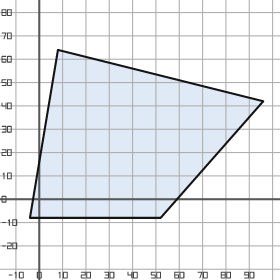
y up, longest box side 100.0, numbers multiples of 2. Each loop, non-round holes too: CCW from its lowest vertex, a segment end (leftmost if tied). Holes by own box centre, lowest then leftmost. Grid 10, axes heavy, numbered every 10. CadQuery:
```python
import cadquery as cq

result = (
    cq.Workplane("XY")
    .moveTo(-4.0, -8.0)
    .lineTo(52.0, -8.0)
    .lineTo(96.0, 42.0)
    .lineTo(8.0, 64.0)
    .close()
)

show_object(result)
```